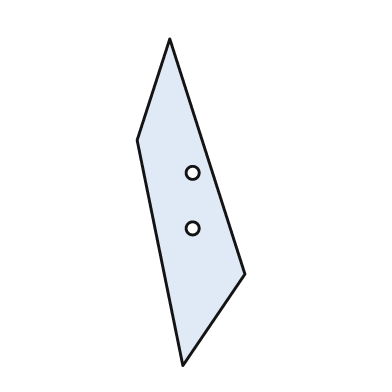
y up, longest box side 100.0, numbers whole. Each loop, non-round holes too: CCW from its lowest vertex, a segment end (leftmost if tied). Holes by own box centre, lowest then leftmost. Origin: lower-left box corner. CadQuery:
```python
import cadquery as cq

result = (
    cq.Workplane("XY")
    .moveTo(14.0, 0.0)
    .lineTo(33.0, 28.0)
    .lineTo(10.0, 100.0)
    .lineTo(0.0, 69.0)
    .close()
    .moveTo(17.0, 42.0)
    .circle(2.0)
    .moveTo(17.0, 59.0)
    .circle(2.0)
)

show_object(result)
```